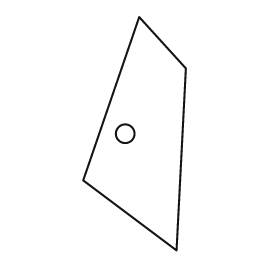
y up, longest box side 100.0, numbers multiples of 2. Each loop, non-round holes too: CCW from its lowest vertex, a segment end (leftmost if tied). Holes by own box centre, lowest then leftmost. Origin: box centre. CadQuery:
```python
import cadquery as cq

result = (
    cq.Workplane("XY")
    .moveTo(18.0, -50.0)
    .lineTo(22.0, 28.0)
    .lineTo(2.0, 50.0)
    .lineTo(-22.0, -20.0)
    .close()
    .moveTo(-4.0, 0.0)
    .circle(4.0)
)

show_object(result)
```